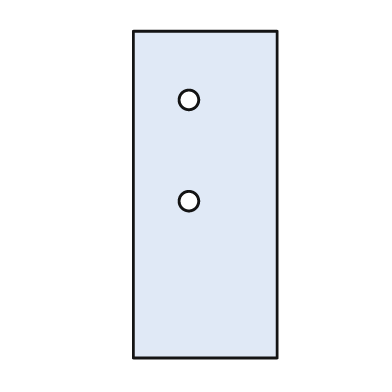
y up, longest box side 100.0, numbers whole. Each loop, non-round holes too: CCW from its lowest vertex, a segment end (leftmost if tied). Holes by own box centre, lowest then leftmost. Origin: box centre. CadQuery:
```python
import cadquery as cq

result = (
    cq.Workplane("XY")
    .moveTo(-22.0, -50.0)
    .lineTo(22.0, -50.0)
    .lineTo(22.0, 50.0)
    .lineTo(-22.0, 50.0)
    .close()
    .moveTo(-5.0, -2.0)
    .circle(3.0)
    .moveTo(-5.0, 29.0)
    .circle(3.0)
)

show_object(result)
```